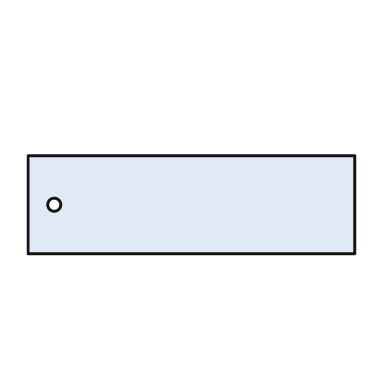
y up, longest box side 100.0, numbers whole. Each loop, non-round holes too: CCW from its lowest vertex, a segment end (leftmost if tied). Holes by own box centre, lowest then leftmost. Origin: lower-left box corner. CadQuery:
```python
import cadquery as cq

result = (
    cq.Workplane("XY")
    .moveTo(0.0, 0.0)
    .lineTo(100.0, 0.0)
    .lineTo(100.0, 30.0)
    .lineTo(0.0, 30.0)
    .close()
    .moveTo(8.0, 15.0)
    .circle(2.0)
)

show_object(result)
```